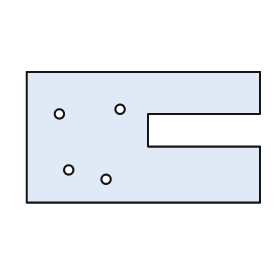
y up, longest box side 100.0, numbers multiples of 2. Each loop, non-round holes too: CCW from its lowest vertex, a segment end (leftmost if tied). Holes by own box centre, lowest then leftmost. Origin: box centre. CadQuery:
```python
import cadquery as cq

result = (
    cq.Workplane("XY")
    .moveTo(-50.0, -28.0)
    .lineTo(50.0, -28.0)
    .lineTo(50.0, -4.0)
    .lineTo(2.0, -4.0)
    .lineTo(2.0, 10.0)
    .lineTo(50.0, 10.0)
    .lineTo(50.0, 28.0)
    .lineTo(-50.0, 28.0)
    .close()
    .moveTo(-16.0, -18.0)
    .circle(2.0)
    .moveTo(-32.0, -14.0)
    .circle(2.0)
    .moveTo(-36.0, 10.0)
    .circle(2.0)
    .moveTo(-10.0, 12.0)
    .circle(2.0)
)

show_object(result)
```